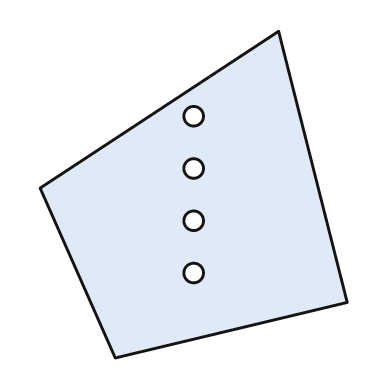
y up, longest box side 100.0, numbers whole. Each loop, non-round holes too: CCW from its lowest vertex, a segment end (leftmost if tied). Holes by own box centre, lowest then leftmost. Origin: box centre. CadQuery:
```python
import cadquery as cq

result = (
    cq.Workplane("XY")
    .moveTo(-24.0, -50.0)
    .lineTo(47.0, -33.0)
    .lineTo(26.0, 50.0)
    .lineTo(-47.0, 2.0)
    .close()
    .moveTo(0.0, -24.0)
    .circle(3.0)
    .moveTo(0.0, -8.0)
    .circle(3.0)
    .moveTo(0.0, 8.0)
    .circle(3.0)
    .moveTo(0.0, 24.0)
    .circle(3.0)
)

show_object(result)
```